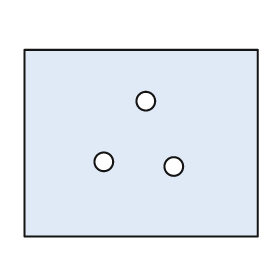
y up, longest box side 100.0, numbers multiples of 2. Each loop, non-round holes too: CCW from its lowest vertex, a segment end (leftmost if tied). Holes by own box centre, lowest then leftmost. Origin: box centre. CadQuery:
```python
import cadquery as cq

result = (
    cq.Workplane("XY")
    .moveTo(-50.0, -40.0)
    .lineTo(50.0, -40.0)
    .lineTo(50.0, 40.0)
    .lineTo(-50.0, 40.0)
    .close()
    .moveTo(14.0, -10.0)
    .circle(4.0)
    .moveTo(-16.0, -8.0)
    .circle(4.0)
    .moveTo(2.0, 18.0)
    .circle(4.0)
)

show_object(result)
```